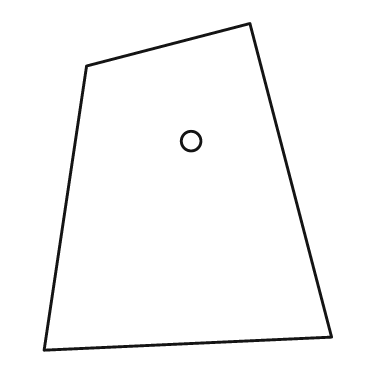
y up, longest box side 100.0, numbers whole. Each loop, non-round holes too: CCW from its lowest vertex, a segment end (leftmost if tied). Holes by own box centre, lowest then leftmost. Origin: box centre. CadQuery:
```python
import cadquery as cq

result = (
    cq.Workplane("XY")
    .moveTo(-44.0, -50.0)
    .lineTo(44.0, -46.0)
    .lineTo(19.0, 50.0)
    .lineTo(-31.0, 37.0)
    .close()
    .moveTo(1.0, 14.0)
    .circle(3.0)
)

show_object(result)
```